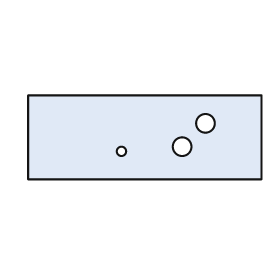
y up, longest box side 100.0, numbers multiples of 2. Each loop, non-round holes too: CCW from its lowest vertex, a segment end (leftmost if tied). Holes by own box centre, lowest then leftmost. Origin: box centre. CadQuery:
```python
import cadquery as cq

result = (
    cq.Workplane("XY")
    .moveTo(-50.0, -18.0)
    .lineTo(50.0, -18.0)
    .lineTo(50.0, 18.0)
    .lineTo(-50.0, 18.0)
    .close()
    .moveTo(-10.0, -6.0)
    .circle(2.0)
    .moveTo(16.0, -4.0)
    .circle(4.0)
    .moveTo(26.0, 6.0)
    .circle(4.0)
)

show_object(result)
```